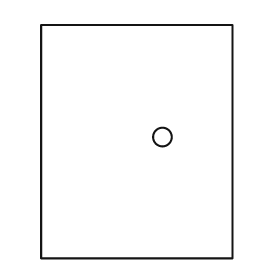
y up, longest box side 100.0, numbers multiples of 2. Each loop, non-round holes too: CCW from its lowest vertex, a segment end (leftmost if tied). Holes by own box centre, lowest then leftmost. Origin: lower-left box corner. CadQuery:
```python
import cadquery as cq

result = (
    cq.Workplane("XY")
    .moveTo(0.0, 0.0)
    .lineTo(82.0, 0.0)
    .lineTo(82.0, 100.0)
    .lineTo(0.0, 100.0)
    .close()
    .moveTo(52.0, 52.0)
    .circle(4.0)
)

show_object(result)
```